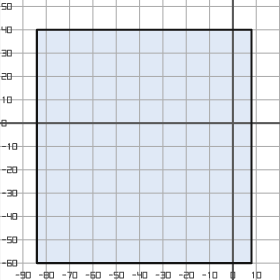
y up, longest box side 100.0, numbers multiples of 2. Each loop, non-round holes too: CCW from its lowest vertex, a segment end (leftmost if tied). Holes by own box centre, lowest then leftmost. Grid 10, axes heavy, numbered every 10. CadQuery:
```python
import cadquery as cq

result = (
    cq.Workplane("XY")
    .moveTo(-84.0, -60.0)
    .lineTo(8.0, -60.0)
    .lineTo(8.0, 40.0)
    .lineTo(-84.0, 40.0)
    .close()
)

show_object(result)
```